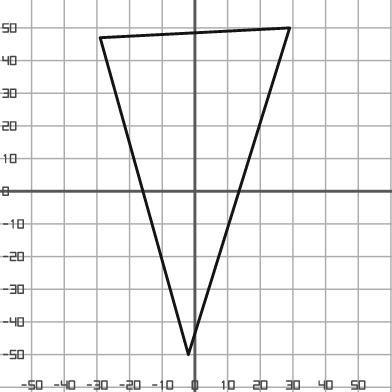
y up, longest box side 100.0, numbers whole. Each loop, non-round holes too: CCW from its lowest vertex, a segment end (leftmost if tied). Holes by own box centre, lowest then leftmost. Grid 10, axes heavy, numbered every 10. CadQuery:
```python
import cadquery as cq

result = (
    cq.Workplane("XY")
    .moveTo(-2.0, -50.0)
    .lineTo(29.0, 50.0)
    .lineTo(-29.0, 47.0)
    .close()
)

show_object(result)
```